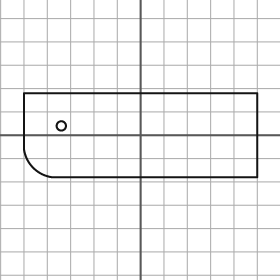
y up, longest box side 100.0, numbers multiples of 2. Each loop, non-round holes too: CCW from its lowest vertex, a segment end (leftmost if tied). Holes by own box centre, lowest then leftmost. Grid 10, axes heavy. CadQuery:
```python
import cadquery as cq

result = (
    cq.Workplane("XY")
    .moveTo(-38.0, -18.0)
    .lineTo(50.0, -18.0)
    .lineTo(50.0, 18.0)
    .lineTo(-50.0, 18.0)
    .lineTo(-50.0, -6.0)
    .threePointArc((-46.0, -14.0), (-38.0, -18.0))
    .close()
    .moveTo(-34.0, 4.0)
    .circle(2.0)
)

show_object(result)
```